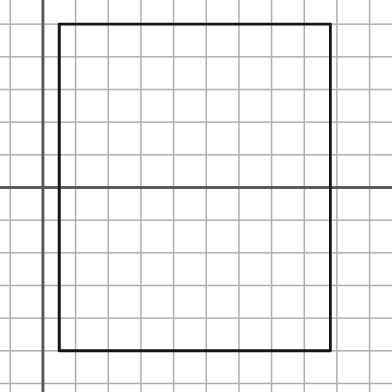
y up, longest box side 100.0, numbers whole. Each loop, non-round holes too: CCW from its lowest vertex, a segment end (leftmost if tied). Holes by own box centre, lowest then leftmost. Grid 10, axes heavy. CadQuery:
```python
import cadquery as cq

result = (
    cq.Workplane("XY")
    .moveTo(5.0, -50.0)
    .lineTo(88.0, -50.0)
    .lineTo(88.0, 50.0)
    .lineTo(5.0, 50.0)
    .close()
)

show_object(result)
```